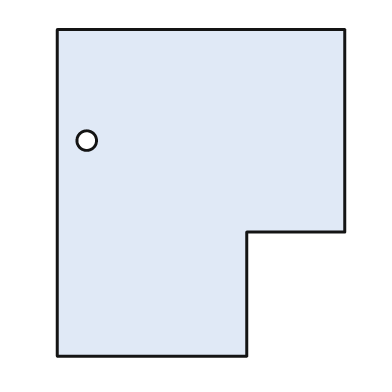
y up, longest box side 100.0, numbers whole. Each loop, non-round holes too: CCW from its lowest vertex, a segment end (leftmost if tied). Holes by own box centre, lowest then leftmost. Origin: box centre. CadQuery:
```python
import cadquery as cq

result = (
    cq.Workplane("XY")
    .moveTo(-44.0, -50.0)
    .lineTo(14.0, -50.0)
    .lineTo(14.0, -12.0)
    .lineTo(44.0, -12.0)
    .lineTo(44.0, 50.0)
    .lineTo(-44.0, 50.0)
    .close()
    .moveTo(-35.0, 16.0)
    .circle(3.0)
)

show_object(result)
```